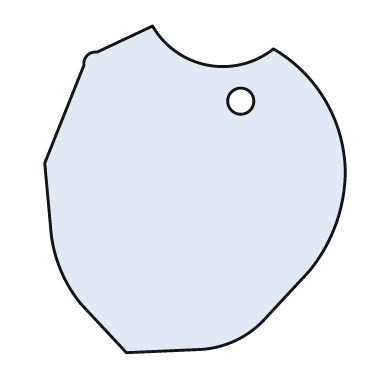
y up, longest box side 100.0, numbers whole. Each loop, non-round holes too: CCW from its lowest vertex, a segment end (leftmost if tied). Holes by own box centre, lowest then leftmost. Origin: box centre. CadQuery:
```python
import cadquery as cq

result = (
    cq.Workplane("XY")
    .moveTo(-21.0, -50.0)
    .lineTo(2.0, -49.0)
    .threePointArc((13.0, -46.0), (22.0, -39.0))
    .lineTo(35.0, -25.0)
    .threePointArc((43.0, -11.0), (46.0, 5.0))
    .threePointArc((40.0, 27.0), (24.0, 43.0))
    .threePointArc((4.0, 38.0), (-13.0, 50.0))
    .lineTo(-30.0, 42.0)
    .threePointArc((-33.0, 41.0), (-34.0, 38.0))
    .lineTo(-46.0, 8.0)
    .lineTo(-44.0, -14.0)
    .threePointArc((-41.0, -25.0), (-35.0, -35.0))
    .close()
    .moveTo(14.0, 27.0)
    .circle(4.0)
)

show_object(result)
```